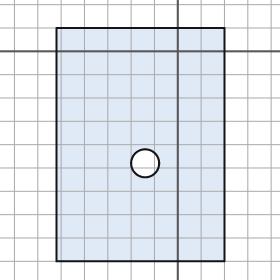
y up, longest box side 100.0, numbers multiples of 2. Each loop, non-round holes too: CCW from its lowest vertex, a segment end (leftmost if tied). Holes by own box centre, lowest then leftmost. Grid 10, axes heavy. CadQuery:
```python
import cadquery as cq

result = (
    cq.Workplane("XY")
    .moveTo(-52.0, -90.0)
    .lineTo(20.0, -90.0)
    .lineTo(20.0, 10.0)
    .lineTo(-52.0, 10.0)
    .close()
    .moveTo(-14.0, -48.0)
    .circle(6.0)
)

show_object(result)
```